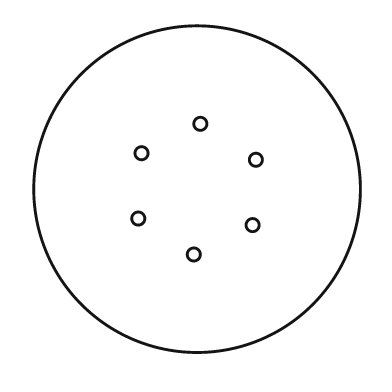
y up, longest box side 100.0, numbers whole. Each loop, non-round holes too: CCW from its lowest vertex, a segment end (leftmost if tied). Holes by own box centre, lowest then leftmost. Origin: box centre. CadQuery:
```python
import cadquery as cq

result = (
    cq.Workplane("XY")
    .moveTo(0.0, 0.0)
    .circle(50.0)
    .moveTo(-1.0, -20.0)
    .circle(2.0)
    .moveTo(17.0, -11.0)
    .circle(2.0)
    .moveTo(-18.0, -9.0)
    .circle(2.0)
    .moveTo(18.0, 9.0)
    .circle(2.0)
    .moveTo(-17.0, 11.0)
    .circle(2.0)
    .moveTo(1.0, 20.0)
    .circle(2.0)
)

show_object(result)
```